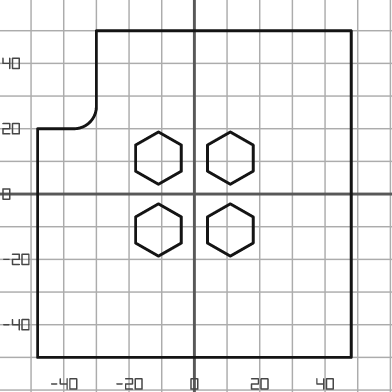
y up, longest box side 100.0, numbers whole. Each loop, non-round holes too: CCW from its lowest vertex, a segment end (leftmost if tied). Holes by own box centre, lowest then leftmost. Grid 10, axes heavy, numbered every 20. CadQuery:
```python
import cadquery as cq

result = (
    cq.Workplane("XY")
    .moveTo(-48.0, -50.0)
    .lineTo(48.0, -50.0)
    .lineTo(48.0, 50.0)
    .lineTo(-30.0, 50.0)
    .lineTo(-30.0, 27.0)
    .threePointArc((-32.0, 22.0), (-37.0, 20.0))
    .lineTo(-48.0, 20.0)
    .close()
    .moveTo(-11.0, -19.0)
    .lineTo(-4.0, -15.0)
    .lineTo(-4.0, -7.0)
    .lineTo(-11.0, -3.0)
    .lineTo(-18.0, -7.0)
    .lineTo(-18.0, -15.0)
    .close()
    .moveTo(11.0, -19.0)
    .lineTo(18.0, -15.0)
    .lineTo(18.0, -7.0)
    .lineTo(11.0, -3.0)
    .lineTo(4.0, -7.0)
    .lineTo(4.0, -15.0)
    .close()
    .moveTo(-11.0, 3.0)
    .lineTo(-4.0, 7.0)
    .lineTo(-4.0, 15.0)
    .lineTo(-11.0, 19.0)
    .lineTo(-18.0, 15.0)
    .lineTo(-18.0, 7.0)
    .close()
    .moveTo(11.0, 3.0)
    .lineTo(18.0, 7.0)
    .lineTo(18.0, 15.0)
    .lineTo(11.0, 19.0)
    .lineTo(4.0, 15.0)
    .lineTo(4.0, 7.0)
    .close()
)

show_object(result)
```